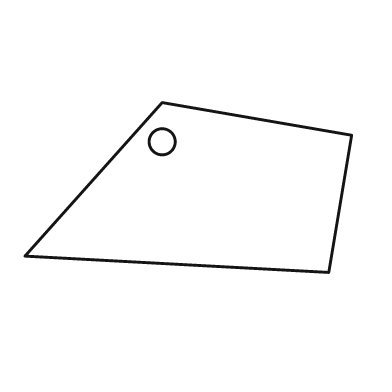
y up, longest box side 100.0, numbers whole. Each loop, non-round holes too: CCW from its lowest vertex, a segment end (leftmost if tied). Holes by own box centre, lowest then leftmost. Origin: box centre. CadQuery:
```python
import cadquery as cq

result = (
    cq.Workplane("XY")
    .moveTo(43.0, -26.0)
    .lineTo(50.0, 16.0)
    .lineTo(-8.0, 26.0)
    .lineTo(-50.0, -21.0)
    .close()
    .moveTo(-8.0, 14.0)
    .circle(4.0)
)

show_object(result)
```